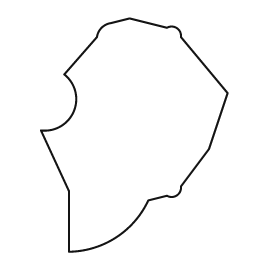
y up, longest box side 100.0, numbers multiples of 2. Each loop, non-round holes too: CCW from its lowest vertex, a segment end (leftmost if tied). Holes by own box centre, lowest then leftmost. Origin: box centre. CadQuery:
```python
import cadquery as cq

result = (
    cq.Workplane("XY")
    .moveTo(-28.0, -50.0)
    .threePointArc((-8.0, -44.0), (6.0, -28.0))
    .lineTo(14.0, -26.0)
    .threePointArc((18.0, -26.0), (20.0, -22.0))
    .lineTo(32.0, -6.0)
    .lineTo(40.0, 18.0)
    .lineTo(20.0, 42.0)
    .threePointArc((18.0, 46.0), (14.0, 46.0))
    .lineTo(-2.0, 50.0)
    .lineTo(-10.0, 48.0)
    .threePointArc((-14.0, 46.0), (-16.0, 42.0))
    .lineTo(-30.0, 26.0)
    .threePointArc((-26.0, 10.0), (-40.0, 2.0))
    .lineTo(-28.0, -24.0)
    .close()
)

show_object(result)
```